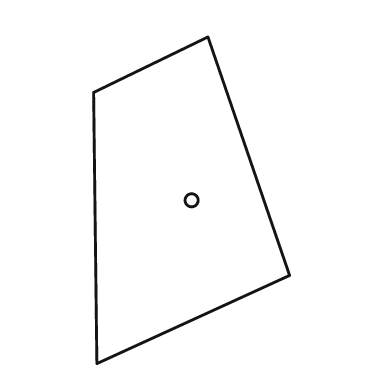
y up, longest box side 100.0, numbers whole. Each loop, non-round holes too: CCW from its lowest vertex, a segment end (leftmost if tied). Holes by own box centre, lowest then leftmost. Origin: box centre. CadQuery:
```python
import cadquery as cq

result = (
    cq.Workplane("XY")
    .moveTo(-29.0, -50.0)
    .lineTo(30.0, -23.0)
    .lineTo(5.0, 50.0)
    .lineTo(-30.0, 33.0)
    .close()
    .moveTo(0.0, 0.0)
    .circle(2.0)
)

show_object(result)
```